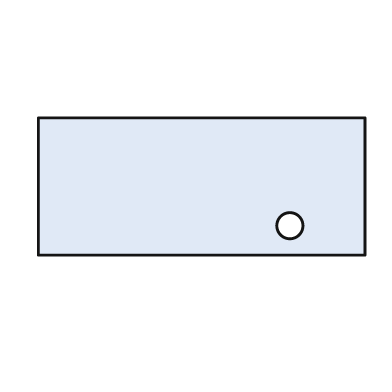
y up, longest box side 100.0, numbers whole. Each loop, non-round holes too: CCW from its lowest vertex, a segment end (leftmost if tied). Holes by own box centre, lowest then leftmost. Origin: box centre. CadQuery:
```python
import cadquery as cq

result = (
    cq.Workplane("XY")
    .moveTo(-50.0, -21.0)
    .lineTo(50.0, -21.0)
    .lineTo(50.0, 21.0)
    .lineTo(-50.0, 21.0)
    .close()
    .moveTo(27.0, -12.0)
    .circle(4.0)
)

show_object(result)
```